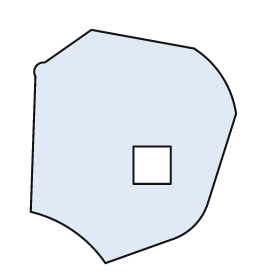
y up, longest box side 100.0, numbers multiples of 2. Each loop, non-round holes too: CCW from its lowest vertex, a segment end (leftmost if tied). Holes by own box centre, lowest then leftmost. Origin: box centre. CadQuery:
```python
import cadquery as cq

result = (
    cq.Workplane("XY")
    .moveTo(-12.0, -50.0)
    .lineTo(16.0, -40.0)
    .threePointArc((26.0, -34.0), (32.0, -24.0))
    .lineTo(44.0, 14.0)
    .threePointArc((38.0, 30.0), (26.0, 42.0))
    .lineTo(-18.0, 50.0)
    .lineTo(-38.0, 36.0)
    .threePointArc((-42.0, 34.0), (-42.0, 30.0))
    .lineTo(-44.0, -28.0)
    .threePointArc((-26.0, -36.0), (-12.0, -50.0))
    .close()
    .moveTo(0.0, -16.0)
    .lineTo(16.0, -16.0)
    .lineTo(16.0, 0.0)
    .lineTo(0.0, 0.0)
    .close()
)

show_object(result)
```